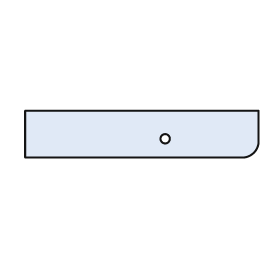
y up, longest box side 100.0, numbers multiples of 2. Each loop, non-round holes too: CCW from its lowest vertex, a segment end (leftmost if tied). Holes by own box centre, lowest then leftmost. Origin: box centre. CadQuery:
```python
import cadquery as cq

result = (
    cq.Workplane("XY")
    .moveTo(-50.0, -10.0)
    .lineTo(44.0, -10.0)
    .threePointArc((48.0, -8.0), (50.0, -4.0))
    .lineTo(50.0, 10.0)
    .lineTo(-50.0, 10.0)
    .close()
    .moveTo(10.0, -2.0)
    .circle(2.0)
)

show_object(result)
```